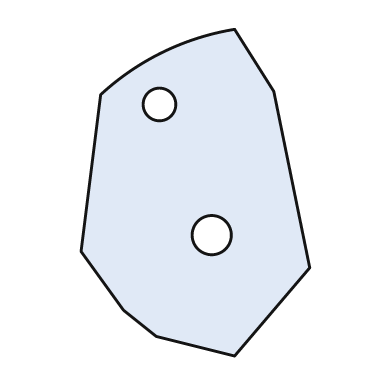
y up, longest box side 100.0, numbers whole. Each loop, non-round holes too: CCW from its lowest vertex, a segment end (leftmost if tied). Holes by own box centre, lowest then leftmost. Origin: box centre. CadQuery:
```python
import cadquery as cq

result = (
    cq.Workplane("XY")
    .moveTo(12.0, -50.0)
    .lineTo(35.0, -23.0)
    .lineTo(24.0, 31.0)
    .lineTo(12.0, 50.0)
    .threePointArc((-10.0, 43.0), (-29.0, 30.0))
    .lineTo(-35.0, -18.0)
    .lineTo(-22.0, -36.0)
    .lineTo(-12.0, -44.0)
    .close()
    .moveTo(5.0, -13.0)
    .circle(6.0)
    .moveTo(-11.0, 27.0)
    .circle(5.0)
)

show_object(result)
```